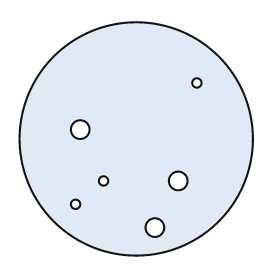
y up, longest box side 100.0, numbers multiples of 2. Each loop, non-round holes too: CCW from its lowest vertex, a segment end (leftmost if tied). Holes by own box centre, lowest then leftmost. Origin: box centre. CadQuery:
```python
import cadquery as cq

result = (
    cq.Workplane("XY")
    .moveTo(0.0, 0.0)
    .circle(50.0)
    .moveTo(8.0, -38.0)
    .circle(4.0)
    .moveTo(-26.0, -28.0)
    .circle(2.0)
    .moveTo(-14.0, -18.0)
    .circle(2.0)
    .moveTo(18.0, -18.0)
    .circle(4.0)
    .moveTo(-24.0, 4.0)
    .circle(4.0)
    .moveTo(26.0, 24.0)
    .circle(2.0)
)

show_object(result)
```